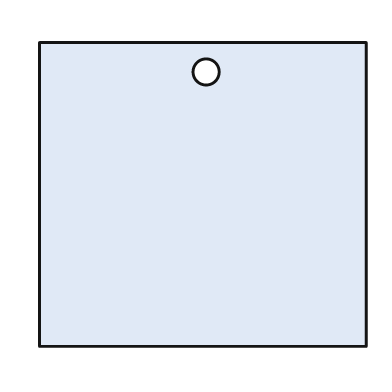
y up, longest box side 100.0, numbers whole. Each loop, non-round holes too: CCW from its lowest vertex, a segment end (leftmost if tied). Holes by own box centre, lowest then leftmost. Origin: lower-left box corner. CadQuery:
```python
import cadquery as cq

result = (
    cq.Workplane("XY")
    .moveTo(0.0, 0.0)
    .lineTo(100.0, 0.0)
    .lineTo(100.0, 93.0)
    .lineTo(0.0, 93.0)
    .close()
    .moveTo(51.0, 84.0)
    .circle(4.0)
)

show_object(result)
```